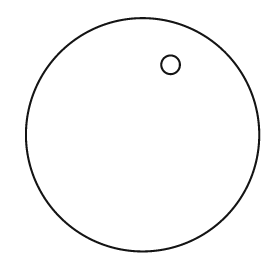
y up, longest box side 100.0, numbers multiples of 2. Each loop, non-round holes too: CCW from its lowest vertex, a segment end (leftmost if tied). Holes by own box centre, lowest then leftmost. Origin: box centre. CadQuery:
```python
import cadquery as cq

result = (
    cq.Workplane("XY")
    .moveTo(0.0, 0.0)
    .circle(50.0)
    .moveTo(12.0, 30.0)
    .circle(4.0)
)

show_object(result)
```